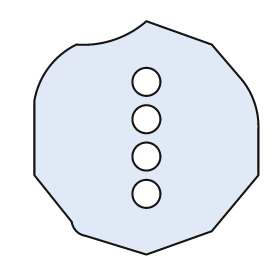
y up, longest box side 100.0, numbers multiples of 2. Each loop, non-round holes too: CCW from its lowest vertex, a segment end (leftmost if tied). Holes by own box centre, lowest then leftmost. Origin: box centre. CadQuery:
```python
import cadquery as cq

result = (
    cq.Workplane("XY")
    .moveTo(0.0, -50.0)
    .lineTo(28.0, -40.0)
    .lineTo(48.0, -16.0)
    .lineTo(48.0, 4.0)
    .threePointArc((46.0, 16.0), (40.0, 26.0))
    .lineTo(28.0, 40.0)
    .lineTo(0.0, 50.0)
    .threePointArc((-14.0, 42.0), (-30.0, 40.0))
    .threePointArc((-42.0, 30.0), (-48.0, 16.0))
    .lineTo(-48.0, -16.0)
    .lineTo(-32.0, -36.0)
    .threePointArc((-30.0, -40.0), (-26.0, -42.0))
    .close()
    .moveTo(0.0, -24.0)
    .circle(6.0)
    .moveTo(0.0, -8.0)
    .circle(6.0)
    .moveTo(0.0, 8.0)
    .circle(6.0)
    .moveTo(0.0, 24.0)
    .circle(6.0)
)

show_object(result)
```